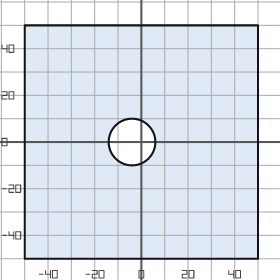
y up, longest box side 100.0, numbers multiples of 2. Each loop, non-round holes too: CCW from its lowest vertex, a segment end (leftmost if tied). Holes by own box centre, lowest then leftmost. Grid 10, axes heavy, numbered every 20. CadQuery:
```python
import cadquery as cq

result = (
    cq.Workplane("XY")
    .moveTo(-50.0, -50.0)
    .lineTo(50.0, -50.0)
    .lineTo(50.0, 50.0)
    .lineTo(-50.0, 50.0)
    .close()
    .moveTo(-4.0, 0.0)
    .circle(10.0)
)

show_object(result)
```